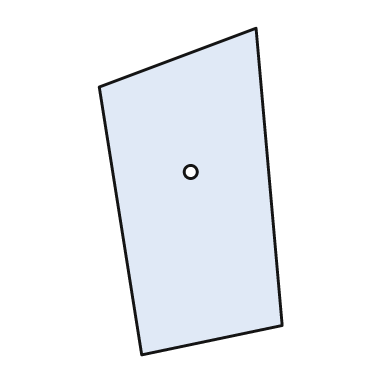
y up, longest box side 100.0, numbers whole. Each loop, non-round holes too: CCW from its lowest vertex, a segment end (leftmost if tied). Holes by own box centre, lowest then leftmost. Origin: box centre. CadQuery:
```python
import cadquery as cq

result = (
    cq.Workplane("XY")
    .moveTo(-15.0, -50.0)
    .lineTo(28.0, -41.0)
    .lineTo(20.0, 50.0)
    .lineTo(-28.0, 32.0)
    .close()
    .moveTo(0.0, 6.0)
    .circle(2.0)
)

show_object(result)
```